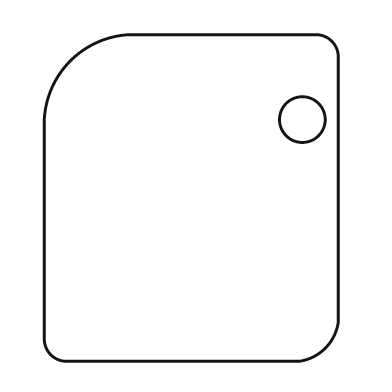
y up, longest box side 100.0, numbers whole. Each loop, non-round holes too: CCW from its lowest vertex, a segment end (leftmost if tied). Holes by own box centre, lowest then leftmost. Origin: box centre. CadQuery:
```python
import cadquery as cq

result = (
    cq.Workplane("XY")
    .moveTo(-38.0, -50.0)
    .lineTo(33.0, -50.0)
    .threePointArc((41.0, -46.0), (45.0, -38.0))
    .lineTo(45.0, 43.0)
    .threePointArc((43.0, 48.0), (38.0, 50.0))
    .lineTo(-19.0, 50.0)
    .threePointArc((-37.0, 42.0), (-45.0, 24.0))
    .lineTo(-45.0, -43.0)
    .threePointArc((-43.0, -48.0), (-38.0, -50.0))
    .close()
    .moveTo(34.0, 24.0)
    .circle(7.0)
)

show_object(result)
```